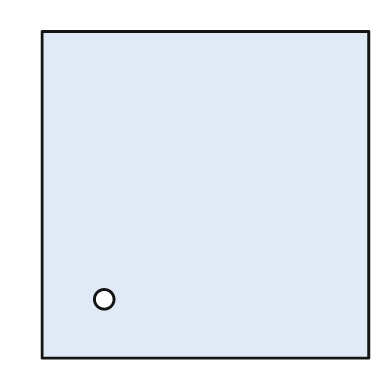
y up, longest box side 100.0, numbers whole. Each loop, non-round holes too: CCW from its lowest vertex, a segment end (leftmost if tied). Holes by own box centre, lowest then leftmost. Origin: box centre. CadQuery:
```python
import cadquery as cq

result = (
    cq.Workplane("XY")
    .moveTo(-50.0, -50.0)
    .lineTo(50.0, -50.0)
    .lineTo(50.0, 50.0)
    .lineTo(-50.0, 50.0)
    .close()
    .moveTo(-31.0, -32.0)
    .circle(3.0)
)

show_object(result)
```